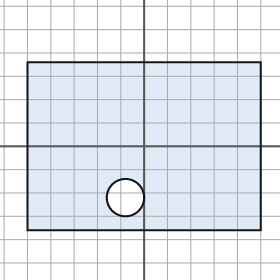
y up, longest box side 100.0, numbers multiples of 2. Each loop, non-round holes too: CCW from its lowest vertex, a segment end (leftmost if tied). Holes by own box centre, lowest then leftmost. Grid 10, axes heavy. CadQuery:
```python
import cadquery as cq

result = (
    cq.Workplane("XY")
    .moveTo(-50.0, -36.0)
    .lineTo(50.0, -36.0)
    .lineTo(50.0, 36.0)
    .lineTo(-50.0, 36.0)
    .close()
    .moveTo(-8.0, -22.0)
    .circle(8.0)
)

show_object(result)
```